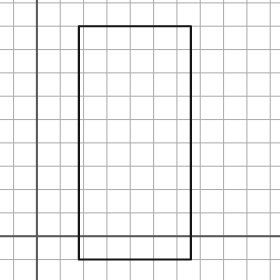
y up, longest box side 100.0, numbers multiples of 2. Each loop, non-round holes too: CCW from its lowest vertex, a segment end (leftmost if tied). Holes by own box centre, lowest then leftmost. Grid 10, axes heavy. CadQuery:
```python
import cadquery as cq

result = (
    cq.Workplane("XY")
    .moveTo(18.0, -10.0)
    .lineTo(66.0, -10.0)
    .lineTo(66.0, 90.0)
    .lineTo(18.0, 90.0)
    .close()
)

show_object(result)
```